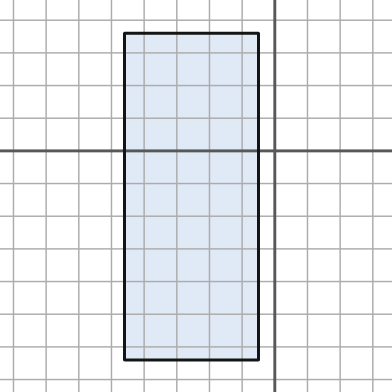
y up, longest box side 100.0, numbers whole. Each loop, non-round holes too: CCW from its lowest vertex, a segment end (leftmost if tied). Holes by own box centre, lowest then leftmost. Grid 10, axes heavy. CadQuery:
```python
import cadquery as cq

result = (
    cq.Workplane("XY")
    .moveTo(-46.0, -64.0)
    .lineTo(-5.0, -64.0)
    .lineTo(-5.0, 36.0)
    .lineTo(-46.0, 36.0)
    .close()
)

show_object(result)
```